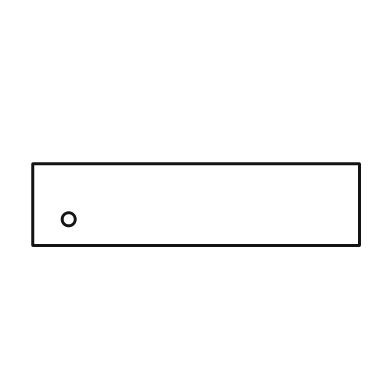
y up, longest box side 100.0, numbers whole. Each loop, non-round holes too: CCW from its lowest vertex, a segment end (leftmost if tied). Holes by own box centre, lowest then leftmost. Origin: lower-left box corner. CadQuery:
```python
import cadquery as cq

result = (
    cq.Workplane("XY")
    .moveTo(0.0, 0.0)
    .lineTo(100.0, 0.0)
    .lineTo(100.0, 25.0)
    .lineTo(0.0, 25.0)
    .close()
    .moveTo(11.0, 8.0)
    .circle(2.0)
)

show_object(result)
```